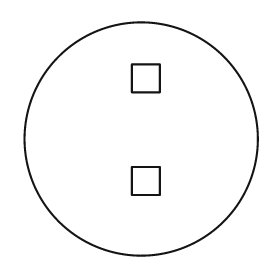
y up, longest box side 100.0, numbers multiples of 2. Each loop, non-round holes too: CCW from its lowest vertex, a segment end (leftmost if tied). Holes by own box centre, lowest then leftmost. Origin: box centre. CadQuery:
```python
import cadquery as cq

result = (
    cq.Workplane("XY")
    .moveTo(0.0, 0.0)
    .circle(50.0)
    .moveTo(-4.0, -24.0)
    .lineTo(8.0, -24.0)
    .lineTo(8.0, -12.0)
    .lineTo(-4.0, -12.0)
    .close()
    .moveTo(-4.0, 20.0)
    .lineTo(8.0, 20.0)
    .lineTo(8.0, 32.0)
    .lineTo(-4.0, 32.0)
    .close()
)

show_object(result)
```